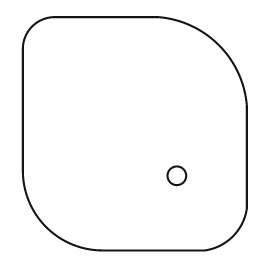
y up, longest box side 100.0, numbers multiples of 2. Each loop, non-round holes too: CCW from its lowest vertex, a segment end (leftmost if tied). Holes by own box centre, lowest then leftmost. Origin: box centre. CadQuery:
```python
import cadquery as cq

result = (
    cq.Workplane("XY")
    .moveTo(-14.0, -50.0)
    .lineTo(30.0, -50.0)
    .threePointArc((42.0, -44.0), (48.0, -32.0))
    .lineTo(48.0, 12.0)
    .threePointArc((36.0, 38.0), (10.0, 50.0))
    .lineTo(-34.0, 50.0)
    .threePointArc((-44.0, 46.0), (-48.0, 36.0))
    .lineTo(-48.0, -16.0)
    .threePointArc((-38.0, -40.0), (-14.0, -50.0))
    .close()
    .moveTo(18.0, -18.0)
    .circle(4.0)
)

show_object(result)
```